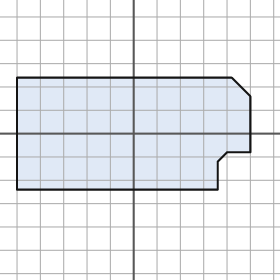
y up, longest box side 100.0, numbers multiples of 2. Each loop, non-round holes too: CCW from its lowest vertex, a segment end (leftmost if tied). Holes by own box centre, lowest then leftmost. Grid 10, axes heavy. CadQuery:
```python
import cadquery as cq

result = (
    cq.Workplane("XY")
    .moveTo(-50.0, -24.0)
    .lineTo(36.0, -24.0)
    .lineTo(36.0, -12.0)
    .lineTo(40.0, -8.0)
    .lineTo(50.0, -8.0)
    .lineTo(50.0, 16.0)
    .lineTo(42.0, 24.0)
    .lineTo(-50.0, 24.0)
    .close()
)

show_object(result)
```